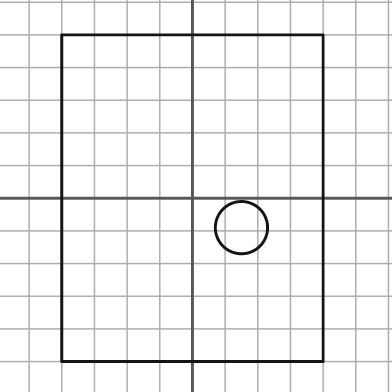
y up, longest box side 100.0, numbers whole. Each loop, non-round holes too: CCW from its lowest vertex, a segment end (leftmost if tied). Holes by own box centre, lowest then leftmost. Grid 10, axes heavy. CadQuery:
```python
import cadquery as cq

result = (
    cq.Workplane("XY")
    .moveTo(-40.0, -50.0)
    .lineTo(40.0, -50.0)
    .lineTo(40.0, 50.0)
    .lineTo(-40.0, 50.0)
    .close()
    .moveTo(15.0, -9.0)
    .circle(8.0)
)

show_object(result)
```